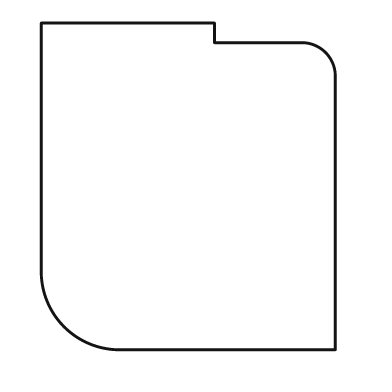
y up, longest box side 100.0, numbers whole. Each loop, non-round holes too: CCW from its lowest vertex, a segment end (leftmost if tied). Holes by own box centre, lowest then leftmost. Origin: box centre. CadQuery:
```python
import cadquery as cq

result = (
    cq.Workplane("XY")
    .moveTo(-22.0, -50.0)
    .lineTo(45.0, -50.0)
    .lineTo(45.0, 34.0)
    .threePointArc((42.0, 41.0), (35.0, 44.0))
    .lineTo(8.0, 44.0)
    .lineTo(8.0, 50.0)
    .lineTo(-45.0, 50.0)
    .lineTo(-45.0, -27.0)
    .threePointArc((-38.0, -43.0), (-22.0, -50.0))
    .close()
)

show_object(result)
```